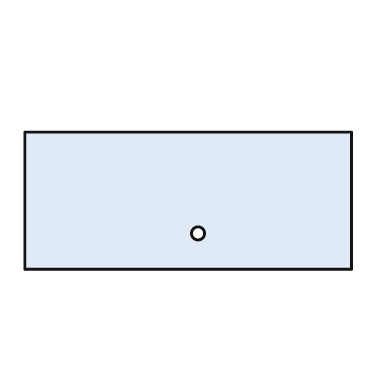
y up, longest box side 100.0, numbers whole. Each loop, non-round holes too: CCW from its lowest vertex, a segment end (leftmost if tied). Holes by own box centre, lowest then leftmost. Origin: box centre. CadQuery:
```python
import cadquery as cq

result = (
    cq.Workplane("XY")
    .moveTo(-50.0, -21.0)
    .lineTo(50.0, -21.0)
    .lineTo(50.0, 21.0)
    .lineTo(-50.0, 21.0)
    .close()
    .moveTo(3.0, -10.0)
    .circle(2.0)
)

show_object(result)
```